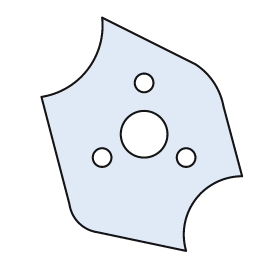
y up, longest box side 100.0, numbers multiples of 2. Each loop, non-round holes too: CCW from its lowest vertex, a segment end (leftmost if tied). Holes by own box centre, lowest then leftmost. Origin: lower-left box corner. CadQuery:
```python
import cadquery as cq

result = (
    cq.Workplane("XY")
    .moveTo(62.0, 0.0)
    .threePointArc((66.0, 22.0), (86.0, 32.0))
    .lineTo(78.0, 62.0)
    .threePointArc((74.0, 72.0), (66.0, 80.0))
    .lineTo(26.0, 100.0)
    .threePointArc((20.0, 78.0), (0.0, 66.0))
    .lineTo(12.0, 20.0)
    .threePointArc((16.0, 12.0), (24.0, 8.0))
    .close()
    .moveTo(26.0, 40.0)
    .circle(4.0)
    .moveTo(62.0, 40.0)
    .circle(4.0)
    .moveTo(44.0, 50.0)
    .circle(10.0)
    .moveTo(44.0, 72.0)
    .circle(4.0)
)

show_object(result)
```